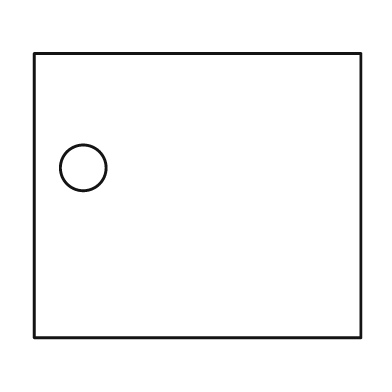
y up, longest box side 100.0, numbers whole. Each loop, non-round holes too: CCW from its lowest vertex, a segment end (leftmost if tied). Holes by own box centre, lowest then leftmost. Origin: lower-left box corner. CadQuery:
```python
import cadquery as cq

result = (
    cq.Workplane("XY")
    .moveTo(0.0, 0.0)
    .lineTo(100.0, 0.0)
    .lineTo(100.0, 87.0)
    .lineTo(0.0, 87.0)
    .close()
    .moveTo(15.0, 52.0)
    .circle(7.0)
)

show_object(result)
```